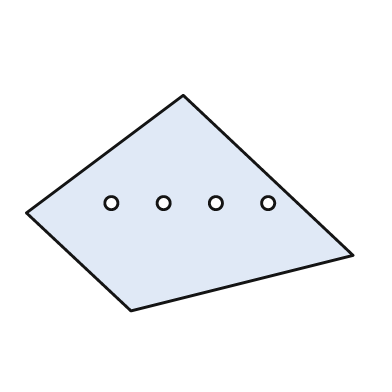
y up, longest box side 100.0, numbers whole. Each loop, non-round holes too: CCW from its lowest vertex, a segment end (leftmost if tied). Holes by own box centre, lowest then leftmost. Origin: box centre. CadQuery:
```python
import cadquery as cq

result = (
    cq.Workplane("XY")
    .moveTo(-18.0, -33.0)
    .lineTo(50.0, -16.0)
    .lineTo(-2.0, 33.0)
    .lineTo(-50.0, -3.0)
    .close()
    .moveTo(-24.0, 0.0)
    .circle(2.0)
    .moveTo(-8.0, 0.0)
    .circle(2.0)
    .moveTo(8.0, 0.0)
    .circle(2.0)
    .moveTo(24.0, 0.0)
    .circle(2.0)
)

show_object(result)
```